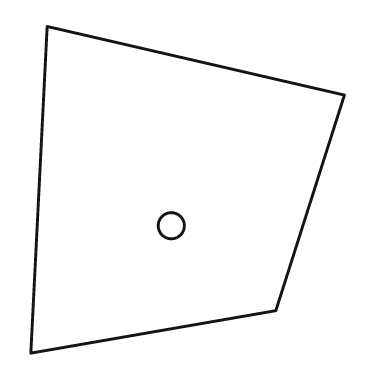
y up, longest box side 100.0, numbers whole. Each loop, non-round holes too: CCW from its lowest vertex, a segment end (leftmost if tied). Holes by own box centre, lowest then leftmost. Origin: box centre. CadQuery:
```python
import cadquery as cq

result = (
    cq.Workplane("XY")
    .moveTo(-48.0, -50.0)
    .lineTo(27.0, -37.0)
    .lineTo(48.0, 29.0)
    .lineTo(-43.0, 50.0)
    .close()
    .moveTo(-5.0, -11.0)
    .circle(4.0)
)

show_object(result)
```